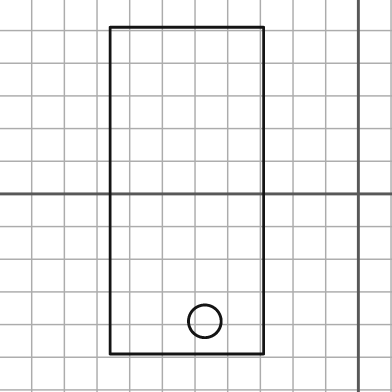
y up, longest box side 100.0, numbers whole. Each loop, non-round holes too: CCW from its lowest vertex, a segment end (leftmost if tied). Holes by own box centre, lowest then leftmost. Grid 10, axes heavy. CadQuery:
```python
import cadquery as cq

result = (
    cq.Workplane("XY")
    .moveTo(-76.0, -49.0)
    .lineTo(-29.0, -49.0)
    .lineTo(-29.0, 51.0)
    .lineTo(-76.0, 51.0)
    .close()
    .moveTo(-47.0, -39.0)
    .circle(5.0)
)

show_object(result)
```